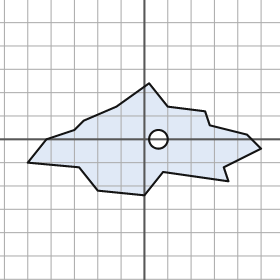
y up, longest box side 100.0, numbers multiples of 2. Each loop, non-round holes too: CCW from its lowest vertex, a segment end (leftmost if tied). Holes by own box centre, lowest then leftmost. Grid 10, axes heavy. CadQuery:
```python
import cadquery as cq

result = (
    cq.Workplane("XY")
    .moveTo(0.0, -24.0)
    .lineTo(8.0, -14.0)
    .lineTo(36.0, -18.0)
    .lineTo(34.0, -12.0)
    .lineTo(50.0, -4.0)
    .lineTo(44.0, 2.0)
    .lineTo(28.0, 6.0)
    .lineTo(26.0, 12.0)
    .lineTo(10.0, 14.0)
    .lineTo(2.0, 24.0)
    .lineTo(-12.0, 14.0)
    .lineTo(-26.0, 8.0)
    .lineTo(-30.0, 4.0)
    .lineTo(-42.0, 0.0)
    .lineTo(-50.0, -10.0)
    .lineTo(-28.0, -12.0)
    .lineTo(-20.0, -22.0)
    .close()
    .moveTo(6.0, 0.0)
    .circle(4.0)
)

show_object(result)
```